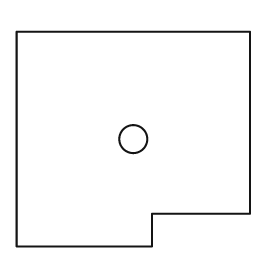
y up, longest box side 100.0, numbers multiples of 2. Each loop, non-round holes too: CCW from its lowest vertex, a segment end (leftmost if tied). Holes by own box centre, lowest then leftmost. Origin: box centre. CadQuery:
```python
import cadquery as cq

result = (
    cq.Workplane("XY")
    .moveTo(-50.0, -46.0)
    .lineTo(8.0, -46.0)
    .lineTo(8.0, -32.0)
    .lineTo(50.0, -32.0)
    .lineTo(50.0, 46.0)
    .lineTo(-50.0, 46.0)
    .close()
    .moveTo(0.0, 0.0)
    .circle(6.0)
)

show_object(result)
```